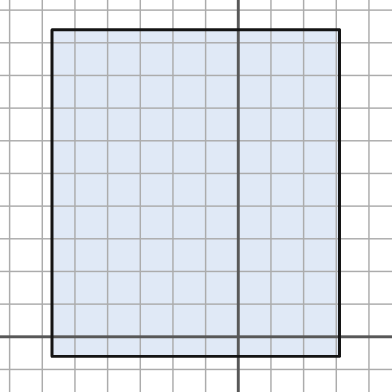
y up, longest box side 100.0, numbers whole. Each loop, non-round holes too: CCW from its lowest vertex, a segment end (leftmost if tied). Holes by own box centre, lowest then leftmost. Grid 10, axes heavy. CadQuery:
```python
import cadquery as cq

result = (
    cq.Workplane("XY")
    .moveTo(-57.0, -6.0)
    .lineTo(31.0, -6.0)
    .lineTo(31.0, 94.0)
    .lineTo(-57.0, 94.0)
    .close()
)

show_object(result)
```